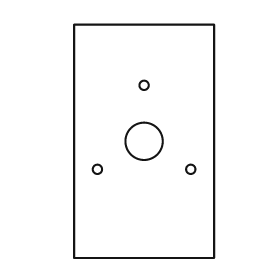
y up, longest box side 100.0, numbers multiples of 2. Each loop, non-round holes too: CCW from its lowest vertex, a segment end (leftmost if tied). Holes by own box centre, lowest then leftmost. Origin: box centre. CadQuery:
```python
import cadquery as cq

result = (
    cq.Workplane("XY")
    .moveTo(-30.0, -50.0)
    .lineTo(30.0, -50.0)
    .lineTo(30.0, 50.0)
    .lineTo(-30.0, 50.0)
    .close()
    .moveTo(-20.0, -12.0)
    .circle(2.0)
    .moveTo(20.0, -12.0)
    .circle(2.0)
    .moveTo(0.0, 0.0)
    .circle(8.0)
    .moveTo(0.0, 24.0)
    .circle(2.0)
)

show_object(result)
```